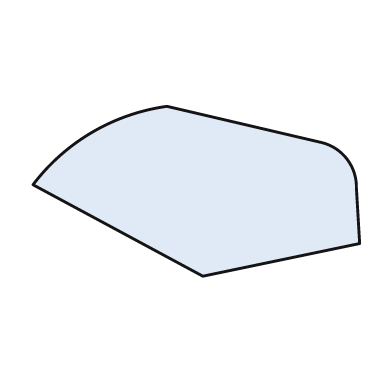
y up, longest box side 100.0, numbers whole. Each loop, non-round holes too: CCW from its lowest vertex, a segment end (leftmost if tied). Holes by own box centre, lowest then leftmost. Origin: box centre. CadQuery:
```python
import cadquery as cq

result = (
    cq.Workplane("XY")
    .moveTo(2.0, -26.0)
    .lineTo(50.0, -16.0)
    .lineTo(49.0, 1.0)
    .threePointArc((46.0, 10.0), (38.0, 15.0))
    .lineTo(-9.0, 26.0)
    .threePointArc((-32.0, 18.0), (-50.0, 2.0))
    .close()
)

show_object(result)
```